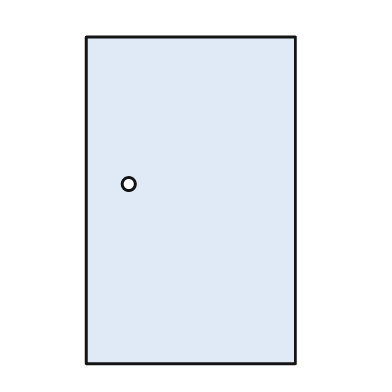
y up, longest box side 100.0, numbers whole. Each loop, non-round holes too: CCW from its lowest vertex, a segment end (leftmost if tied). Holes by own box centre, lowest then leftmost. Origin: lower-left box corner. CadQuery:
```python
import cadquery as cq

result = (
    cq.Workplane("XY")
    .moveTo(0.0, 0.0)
    .lineTo(64.0, 0.0)
    .lineTo(64.0, 100.0)
    .lineTo(0.0, 100.0)
    .close()
    .moveTo(13.0, 55.0)
    .circle(2.0)
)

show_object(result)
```